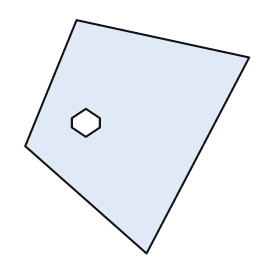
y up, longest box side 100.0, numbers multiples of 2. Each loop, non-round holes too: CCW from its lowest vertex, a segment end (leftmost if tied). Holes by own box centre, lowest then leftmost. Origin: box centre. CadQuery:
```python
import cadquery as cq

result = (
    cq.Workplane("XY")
    .moveTo(4.0, -50.0)
    .lineTo(48.0, 34.0)
    .lineTo(-26.0, 50.0)
    .lineTo(-48.0, -4.0)
    .close()
    .moveTo(-22.0, 0.0)
    .lineTo(-16.0, 4.0)
    .lineTo(-16.0, 8.0)
    .lineTo(-22.0, 12.0)
    .lineTo(-28.0, 8.0)
    .lineTo(-28.0, 4.0)
    .close()
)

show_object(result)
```